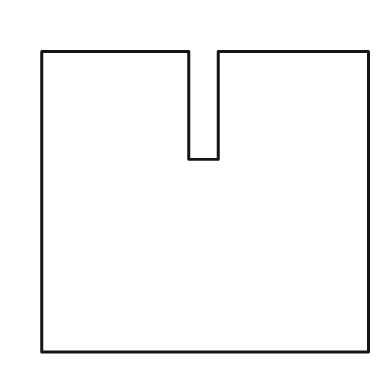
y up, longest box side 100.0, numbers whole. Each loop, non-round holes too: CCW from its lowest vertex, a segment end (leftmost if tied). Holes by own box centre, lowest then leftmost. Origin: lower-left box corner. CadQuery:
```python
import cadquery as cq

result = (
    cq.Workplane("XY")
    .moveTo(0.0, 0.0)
    .lineTo(100.0, 0.0)
    .lineTo(100.0, 92.0)
    .lineTo(54.0, 92.0)
    .lineTo(54.0, 59.0)
    .lineTo(45.0, 59.0)
    .lineTo(45.0, 92.0)
    .lineTo(0.0, 92.0)
    .close()
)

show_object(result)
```